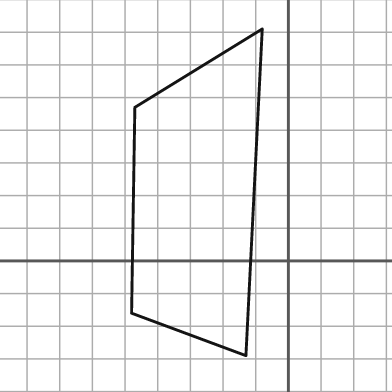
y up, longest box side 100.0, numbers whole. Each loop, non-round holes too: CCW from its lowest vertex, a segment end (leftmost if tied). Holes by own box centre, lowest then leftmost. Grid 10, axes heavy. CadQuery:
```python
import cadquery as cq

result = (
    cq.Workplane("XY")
    .moveTo(-13.0, -29.0)
    .lineTo(-8.0, 71.0)
    .lineTo(-47.0, 47.0)
    .lineTo(-48.0, -16.0)
    .close()
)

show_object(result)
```